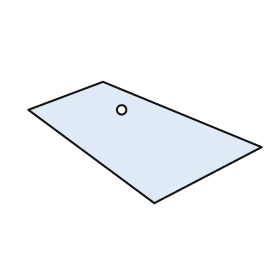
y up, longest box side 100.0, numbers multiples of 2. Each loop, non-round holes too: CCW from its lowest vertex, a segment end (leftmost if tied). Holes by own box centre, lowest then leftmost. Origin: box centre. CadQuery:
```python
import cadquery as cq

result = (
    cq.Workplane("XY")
    .moveTo(4.0, -26.0)
    .lineTo(50.0, -2.0)
    .lineTo(-18.0, 26.0)
    .lineTo(-50.0, 14.0)
    .close()
    .moveTo(-10.0, 14.0)
    .circle(2.0)
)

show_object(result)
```